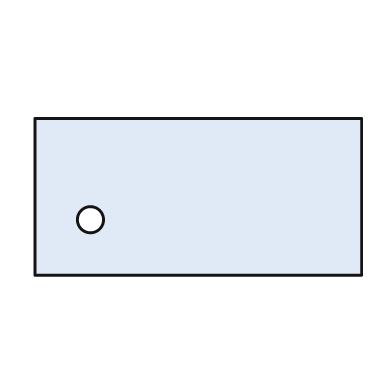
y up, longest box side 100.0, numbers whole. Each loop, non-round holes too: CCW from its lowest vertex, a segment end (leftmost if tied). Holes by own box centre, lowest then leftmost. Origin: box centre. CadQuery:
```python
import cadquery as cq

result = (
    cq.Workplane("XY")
    .moveTo(-50.0, -24.0)
    .lineTo(50.0, -24.0)
    .lineTo(50.0, 24.0)
    .lineTo(-50.0, 24.0)
    .close()
    .moveTo(-33.0, -7.0)
    .circle(4.0)
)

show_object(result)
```